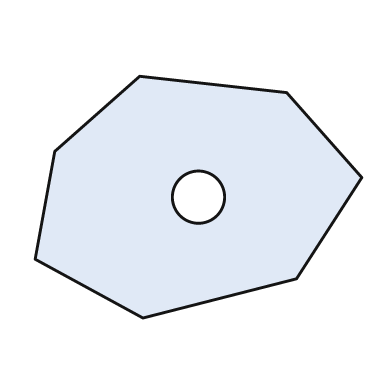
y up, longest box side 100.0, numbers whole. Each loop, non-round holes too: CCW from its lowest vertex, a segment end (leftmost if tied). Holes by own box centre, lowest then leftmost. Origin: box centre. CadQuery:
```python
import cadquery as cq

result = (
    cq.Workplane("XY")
    .moveTo(-17.0, -37.0)
    .lineTo(30.0, -25.0)
    .lineTo(50.0, 6.0)
    .lineTo(27.0, 32.0)
    .lineTo(-18.0, 37.0)
    .lineTo(-44.0, 14.0)
    .lineTo(-50.0, -19.0)
    .close()
    .moveTo(0.0, 0.0)
    .circle(8.0)
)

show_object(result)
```